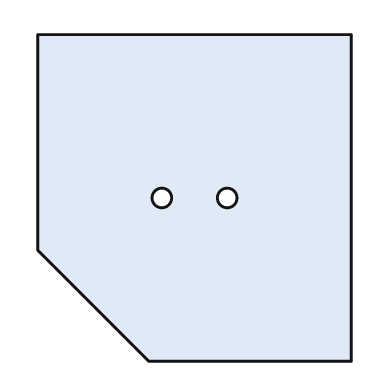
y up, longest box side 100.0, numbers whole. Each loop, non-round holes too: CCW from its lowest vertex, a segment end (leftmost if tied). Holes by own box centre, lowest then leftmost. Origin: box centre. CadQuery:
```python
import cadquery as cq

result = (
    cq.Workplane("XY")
    .moveTo(-14.0, -50.0)
    .lineTo(48.0, -50.0)
    .lineTo(48.0, 50.0)
    .lineTo(-48.0, 50.0)
    .lineTo(-48.0, -16.0)
    .close()
    .moveTo(-10.0, 0.0)
    .circle(3.0)
    .moveTo(10.0, 0.0)
    .circle(3.0)
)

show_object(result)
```